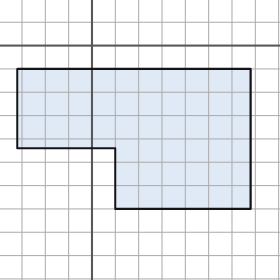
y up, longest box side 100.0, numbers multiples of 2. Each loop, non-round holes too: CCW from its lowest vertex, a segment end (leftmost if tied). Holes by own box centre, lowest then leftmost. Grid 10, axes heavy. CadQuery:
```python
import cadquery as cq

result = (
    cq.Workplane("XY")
    .moveTo(10.0, -70.0)
    .lineTo(68.0, -70.0)
    .lineTo(68.0, -10.0)
    .lineTo(-32.0, -10.0)
    .lineTo(-32.0, -44.0)
    .lineTo(10.0, -44.0)
    .close()
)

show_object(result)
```